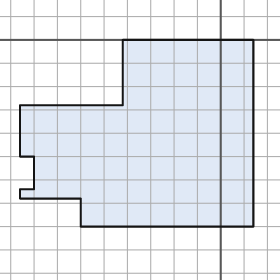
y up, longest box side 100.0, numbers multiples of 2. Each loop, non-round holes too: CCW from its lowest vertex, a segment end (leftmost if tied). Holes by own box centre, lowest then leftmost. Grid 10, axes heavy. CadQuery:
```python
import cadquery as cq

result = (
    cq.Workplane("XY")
    .moveTo(-60.0, -80.0)
    .lineTo(14.0, -80.0)
    .lineTo(14.0, 0.0)
    .lineTo(-42.0, 0.0)
    .lineTo(-42.0, -28.0)
    .lineTo(-86.0, -28.0)
    .lineTo(-86.0, -50.0)
    .lineTo(-80.0, -50.0)
    .lineTo(-80.0, -64.0)
    .lineTo(-86.0, -64.0)
    .lineTo(-86.0, -68.0)
    .lineTo(-60.0, -68.0)
    .close()
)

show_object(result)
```